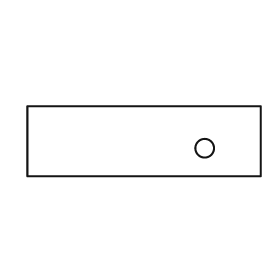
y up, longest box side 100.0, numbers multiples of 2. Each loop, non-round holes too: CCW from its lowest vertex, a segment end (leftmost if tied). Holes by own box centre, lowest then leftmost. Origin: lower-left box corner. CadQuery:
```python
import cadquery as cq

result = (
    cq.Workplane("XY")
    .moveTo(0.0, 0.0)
    .lineTo(100.0, 0.0)
    .lineTo(100.0, 30.0)
    .lineTo(0.0, 30.0)
    .close()
    .moveTo(76.0, 12.0)
    .circle(4.0)
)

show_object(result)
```